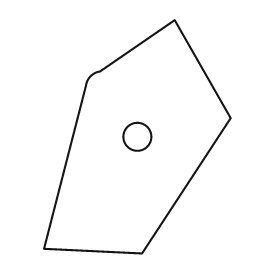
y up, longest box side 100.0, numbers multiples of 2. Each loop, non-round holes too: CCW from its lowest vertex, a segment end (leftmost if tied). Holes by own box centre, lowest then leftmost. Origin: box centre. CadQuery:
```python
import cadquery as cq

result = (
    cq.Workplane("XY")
    .moveTo(2.0, -50.0)
    .lineTo(40.0, 8.0)
    .lineTo(16.0, 50.0)
    .lineTo(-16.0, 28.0)
    .threePointArc((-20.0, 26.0), (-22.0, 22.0))
    .lineTo(-40.0, -48.0)
    .close()
    .moveTo(0.0, 0.0)
    .circle(6.0)
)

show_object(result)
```